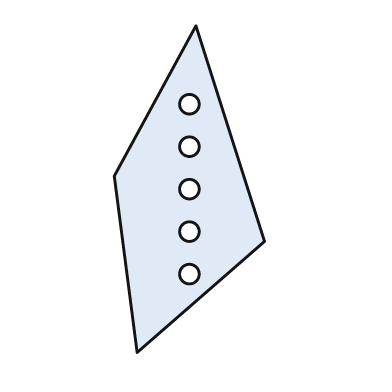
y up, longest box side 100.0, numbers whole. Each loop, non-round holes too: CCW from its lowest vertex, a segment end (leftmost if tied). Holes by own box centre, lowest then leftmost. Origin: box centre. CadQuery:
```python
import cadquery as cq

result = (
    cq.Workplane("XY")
    .moveTo(-16.0, -50.0)
    .lineTo(23.0, -16.0)
    .lineTo(2.0, 50.0)
    .lineTo(-23.0, 4.0)
    .close()
    .moveTo(0.0, -26.0)
    .circle(3.0)
    .moveTo(0.0, -13.0)
    .circle(3.0)
    .moveTo(0.0, 0.0)
    .circle(3.0)
    .moveTo(0.0, 13.0)
    .circle(3.0)
    .moveTo(0.0, 26.0)
    .circle(3.0)
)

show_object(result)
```